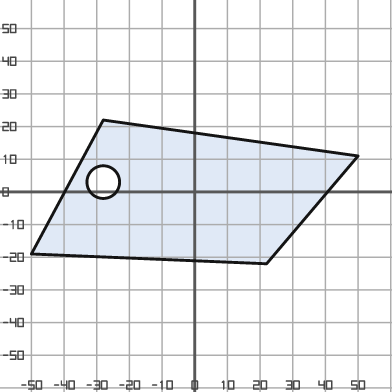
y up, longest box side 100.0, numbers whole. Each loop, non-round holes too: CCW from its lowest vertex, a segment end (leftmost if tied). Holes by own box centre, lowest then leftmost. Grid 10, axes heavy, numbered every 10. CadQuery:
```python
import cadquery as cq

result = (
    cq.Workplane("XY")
    .moveTo(22.0, -22.0)
    .lineTo(50.0, 11.0)
    .lineTo(-28.0, 22.0)
    .lineTo(-50.0, -19.0)
    .close()
    .moveTo(-28.0, 3.0)
    .circle(5.0)
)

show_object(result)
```